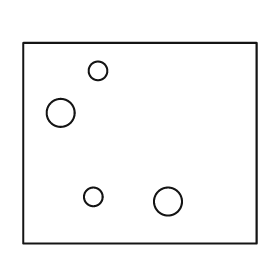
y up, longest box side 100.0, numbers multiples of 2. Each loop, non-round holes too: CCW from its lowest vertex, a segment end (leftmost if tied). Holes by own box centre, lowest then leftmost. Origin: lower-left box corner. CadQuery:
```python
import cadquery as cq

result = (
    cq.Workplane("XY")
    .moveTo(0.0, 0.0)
    .lineTo(100.0, 0.0)
    .lineTo(100.0, 86.0)
    .lineTo(0.0, 86.0)
    .close()
    .moveTo(62.0, 18.0)
    .circle(6.0)
    .moveTo(30.0, 20.0)
    .circle(4.0)
    .moveTo(16.0, 56.0)
    .circle(6.0)
    .moveTo(32.0, 74.0)
    .circle(4.0)
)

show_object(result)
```